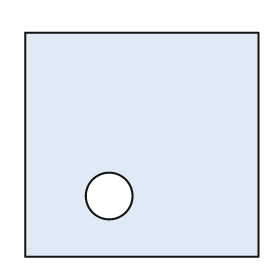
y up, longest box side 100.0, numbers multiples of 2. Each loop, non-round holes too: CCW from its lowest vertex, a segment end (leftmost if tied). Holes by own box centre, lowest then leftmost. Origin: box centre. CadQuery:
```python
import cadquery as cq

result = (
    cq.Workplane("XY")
    .moveTo(-50.0, -48.0)
    .lineTo(50.0, -48.0)
    .lineTo(50.0, 48.0)
    .lineTo(-50.0, 48.0)
    .close()
    .moveTo(-14.0, -22.0)
    .circle(10.0)
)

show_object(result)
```